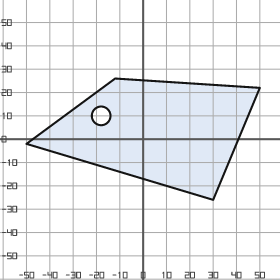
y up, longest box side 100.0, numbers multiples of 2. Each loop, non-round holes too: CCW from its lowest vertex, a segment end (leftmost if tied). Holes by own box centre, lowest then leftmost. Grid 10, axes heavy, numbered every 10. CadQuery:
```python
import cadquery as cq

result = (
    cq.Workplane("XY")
    .moveTo(30.0, -26.0)
    .lineTo(50.0, 22.0)
    .lineTo(-12.0, 26.0)
    .lineTo(-50.0, -2.0)
    .close()
    .moveTo(-18.0, 10.0)
    .circle(4.0)
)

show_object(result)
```